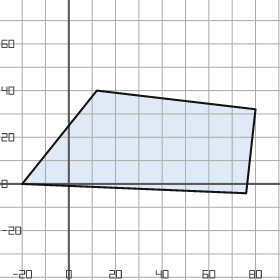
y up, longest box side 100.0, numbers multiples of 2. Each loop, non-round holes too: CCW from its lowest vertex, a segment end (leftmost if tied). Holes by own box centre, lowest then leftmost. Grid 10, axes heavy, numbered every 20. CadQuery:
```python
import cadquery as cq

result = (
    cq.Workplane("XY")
    .moveTo(76.0, -4.0)
    .lineTo(80.0, 32.0)
    .lineTo(12.0, 40.0)
    .lineTo(-20.0, 0.0)
    .close()
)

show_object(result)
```